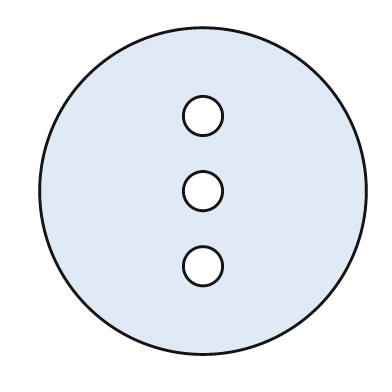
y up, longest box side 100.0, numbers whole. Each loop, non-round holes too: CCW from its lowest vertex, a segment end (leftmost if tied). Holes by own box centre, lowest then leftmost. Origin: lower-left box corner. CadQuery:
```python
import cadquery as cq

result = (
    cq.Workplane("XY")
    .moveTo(50.0, 50.0)
    .circle(50.0)
    .moveTo(50.0, 27.0)
    .circle(6.0)
    .moveTo(50.0, 50.0)
    .circle(6.0)
    .moveTo(50.0, 73.0)
    .circle(6.0)
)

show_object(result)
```